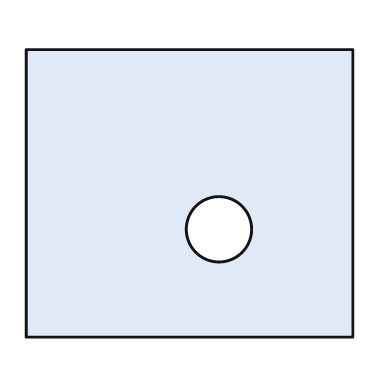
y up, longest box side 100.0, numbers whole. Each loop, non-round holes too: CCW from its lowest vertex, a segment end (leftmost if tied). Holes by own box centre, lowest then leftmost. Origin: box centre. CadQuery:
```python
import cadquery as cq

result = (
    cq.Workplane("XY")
    .moveTo(-50.0, -44.0)
    .lineTo(50.0, -44.0)
    .lineTo(50.0, 44.0)
    .lineTo(-50.0, 44.0)
    .close()
    .moveTo(9.0, -11.0)
    .circle(10.0)
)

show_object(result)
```